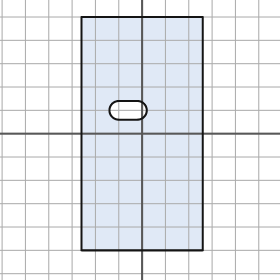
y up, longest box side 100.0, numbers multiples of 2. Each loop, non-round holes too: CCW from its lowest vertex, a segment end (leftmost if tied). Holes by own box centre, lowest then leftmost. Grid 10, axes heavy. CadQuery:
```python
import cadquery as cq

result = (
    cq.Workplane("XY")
    .moveTo(-26.0, -50.0)
    .lineTo(26.0, -50.0)
    .lineTo(26.0, 50.0)
    .lineTo(-26.0, 50.0)
    .close()
    .moveTo(-10.0, 6.0)
    .lineTo(-2.0, 6.0)
    .threePointArc((2.0, 10.0), (-2.0, 14.0))
    .lineTo(-10.0, 14.0)
    .threePointArc((-14.0, 10.0), (-10.0, 6.0))
    .close()
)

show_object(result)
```